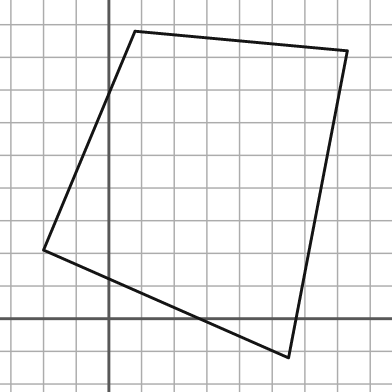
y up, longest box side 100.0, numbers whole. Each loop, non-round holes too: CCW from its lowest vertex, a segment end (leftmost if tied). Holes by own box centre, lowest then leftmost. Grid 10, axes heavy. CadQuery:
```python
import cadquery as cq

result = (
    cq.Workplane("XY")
    .moveTo(55.0, -12.0)
    .lineTo(73.0, 82.0)
    .lineTo(8.0, 88.0)
    .lineTo(-20.0, 21.0)
    .close()
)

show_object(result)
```